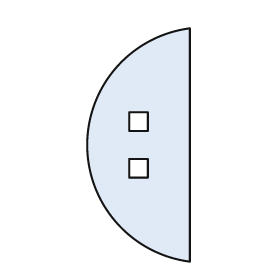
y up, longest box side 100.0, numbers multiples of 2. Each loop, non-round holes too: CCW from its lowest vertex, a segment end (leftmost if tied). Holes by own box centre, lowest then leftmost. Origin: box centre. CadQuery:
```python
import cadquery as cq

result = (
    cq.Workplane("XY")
    .moveTo(22.0, -50.0)
    .lineTo(22.0, 50.0)
    .threePointArc((-22.0, 0.0), (22.0, -50.0))
    .close()
    .moveTo(-4.0, -14.0)
    .lineTo(4.0, -14.0)
    .lineTo(4.0, -6.0)
    .lineTo(-4.0, -6.0)
    .close()
    .moveTo(-4.0, 6.0)
    .lineTo(4.0, 6.0)
    .lineTo(4.0, 14.0)
    .lineTo(-4.0, 14.0)
    .close()
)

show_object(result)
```